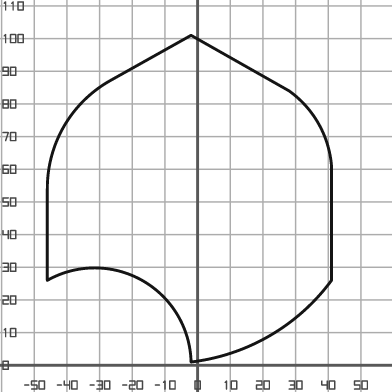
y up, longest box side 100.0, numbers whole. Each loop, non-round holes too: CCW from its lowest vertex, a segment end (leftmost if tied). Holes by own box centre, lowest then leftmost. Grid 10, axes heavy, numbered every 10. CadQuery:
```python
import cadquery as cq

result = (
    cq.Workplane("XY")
    .moveTo(-2.0, 1.0)
    .threePointArc((22.0, 9.0), (41.0, 26.0))
    .lineTo(41.0, 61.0)
    .threePointArc((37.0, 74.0), (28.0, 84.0))
    .lineTo(-2.0, 101.0)
    .lineTo(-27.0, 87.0)
    .threePointArc((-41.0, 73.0), (-46.0, 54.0))
    .lineTo(-46.0, 26.0)
    .threePointArc((-17.0, 26.0), (-2.0, 1.0))
    .close()
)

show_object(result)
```